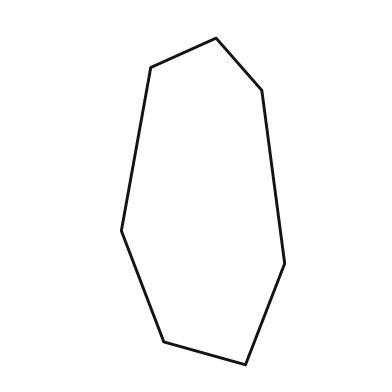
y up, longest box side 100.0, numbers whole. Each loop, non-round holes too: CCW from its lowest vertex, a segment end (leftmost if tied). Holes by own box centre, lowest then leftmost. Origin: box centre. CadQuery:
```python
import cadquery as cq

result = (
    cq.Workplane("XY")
    .moveTo(13.0, -50.0)
    .lineTo(25.0, -19.0)
    .lineTo(18.0, 34.0)
    .lineTo(4.0, 50.0)
    .lineTo(-16.0, 41.0)
    .lineTo(-25.0, -9.0)
    .lineTo(-12.0, -43.0)
    .close()
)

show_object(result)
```